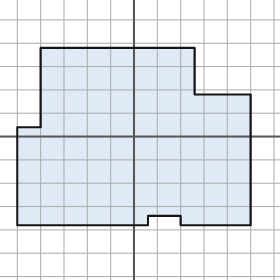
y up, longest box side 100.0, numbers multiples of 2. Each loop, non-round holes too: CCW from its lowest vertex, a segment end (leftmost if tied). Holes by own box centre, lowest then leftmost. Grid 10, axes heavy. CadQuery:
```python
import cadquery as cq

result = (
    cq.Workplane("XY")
    .moveTo(-50.0, -38.0)
    .lineTo(6.0, -38.0)
    .lineTo(6.0, -34.0)
    .lineTo(20.0, -34.0)
    .lineTo(20.0, -38.0)
    .lineTo(50.0, -38.0)
    .lineTo(50.0, 18.0)
    .lineTo(26.0, 18.0)
    .lineTo(26.0, 38.0)
    .lineTo(-40.0, 38.0)
    .lineTo(-40.0, 4.0)
    .lineTo(-50.0, 4.0)
    .close()
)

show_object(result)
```